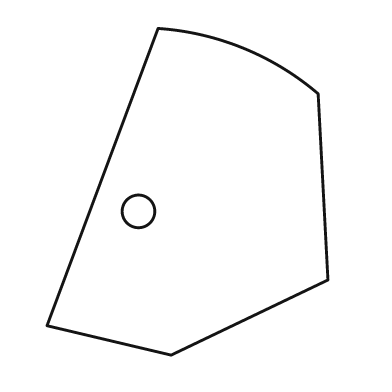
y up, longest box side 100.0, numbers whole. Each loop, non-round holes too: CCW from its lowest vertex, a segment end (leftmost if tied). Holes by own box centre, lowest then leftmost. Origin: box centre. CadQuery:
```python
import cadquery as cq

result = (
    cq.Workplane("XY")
    .moveTo(-5.0, -50.0)
    .lineTo(43.0, -27.0)
    .lineTo(40.0, 30.0)
    .threePointArc((17.0, 44.0), (-9.0, 50.0))
    .lineTo(-43.0, -41.0)
    .close()
    .moveTo(-15.0, -6.0)
    .circle(5.0)
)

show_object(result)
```